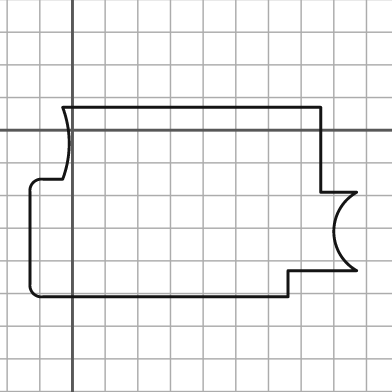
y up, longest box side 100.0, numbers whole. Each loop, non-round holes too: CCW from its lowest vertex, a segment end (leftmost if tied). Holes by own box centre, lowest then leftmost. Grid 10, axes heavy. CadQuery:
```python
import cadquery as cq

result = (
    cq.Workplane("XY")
    .moveTo(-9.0, -51.0)
    .lineTo(66.0, -51.0)
    .lineTo(66.0, -43.0)
    .lineTo(87.0, -43.0)
    .threePointArc((80.0, -31.0), (87.0, -19.0))
    .lineTo(76.0, -19.0)
    .lineTo(76.0, 7.0)
    .lineTo(-3.0, 7.0)
    .threePointArc((-1.0, -4.0), (-3.0, -15.0))
    .lineTo(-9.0, -15.0)
    .threePointArc((-12.0, -16.0), (-13.0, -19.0))
    .lineTo(-13.0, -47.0)
    .threePointArc((-12.0, -50.0), (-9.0, -51.0))
    .close()
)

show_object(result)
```